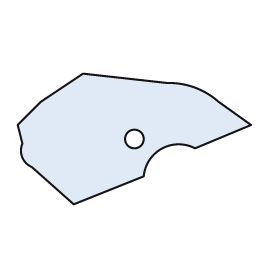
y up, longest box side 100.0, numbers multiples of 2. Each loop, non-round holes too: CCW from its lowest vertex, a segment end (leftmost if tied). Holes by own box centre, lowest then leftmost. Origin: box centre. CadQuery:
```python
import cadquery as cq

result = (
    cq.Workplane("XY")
    .moveTo(-26.0, -28.0)
    .lineTo(4.0, -16.0)
    .threePointArc((12.0, -4.0), (26.0, -4.0))
    .lineTo(50.0, 6.0)
    .lineTo(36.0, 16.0)
    .threePointArc((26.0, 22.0), (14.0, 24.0))
    .lineTo(-22.0, 28.0)
    .lineTo(-40.0, 16.0)
    .lineTo(-50.0, 6.0)
    .lineTo(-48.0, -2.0)
    .threePointArc((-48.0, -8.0), (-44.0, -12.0))
    .close()
    .moveTo(0.0, 0.0)
    .circle(4.0)
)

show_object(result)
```